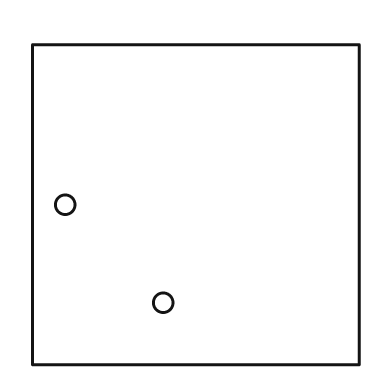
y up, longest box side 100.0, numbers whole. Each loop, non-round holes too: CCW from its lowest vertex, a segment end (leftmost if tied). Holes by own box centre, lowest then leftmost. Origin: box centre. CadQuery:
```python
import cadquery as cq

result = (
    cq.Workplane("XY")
    .moveTo(-50.0, -49.0)
    .lineTo(50.0, -49.0)
    .lineTo(50.0, 49.0)
    .lineTo(-50.0, 49.0)
    .close()
    .moveTo(-10.0, -30.0)
    .circle(3.0)
    .moveTo(-40.0, 0.0)
    .circle(3.0)
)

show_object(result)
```